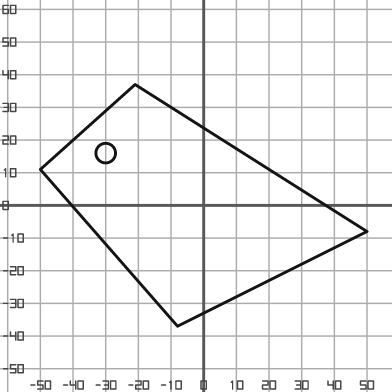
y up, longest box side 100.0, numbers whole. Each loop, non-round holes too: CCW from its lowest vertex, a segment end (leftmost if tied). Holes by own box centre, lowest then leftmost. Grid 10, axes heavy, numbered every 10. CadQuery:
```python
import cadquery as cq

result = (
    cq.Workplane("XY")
    .moveTo(-8.0, -37.0)
    .lineTo(50.0, -8.0)
    .lineTo(-21.0, 37.0)
    .lineTo(-50.0, 11.0)
    .close()
    .moveTo(-30.0, 16.0)
    .circle(3.0)
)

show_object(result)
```